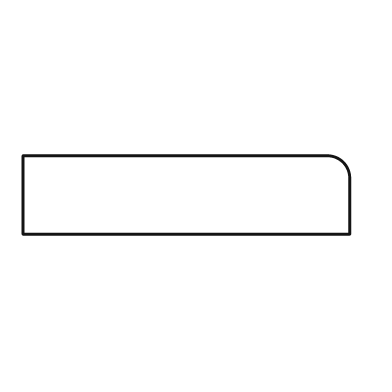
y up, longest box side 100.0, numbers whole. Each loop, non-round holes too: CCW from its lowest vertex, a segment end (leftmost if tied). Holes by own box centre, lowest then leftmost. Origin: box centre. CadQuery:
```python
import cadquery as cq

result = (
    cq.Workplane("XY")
    .moveTo(-50.0, -12.0)
    .lineTo(50.0, -12.0)
    .lineTo(50.0, 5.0)
    .threePointArc((48.0, 10.0), (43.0, 12.0))
    .lineTo(-50.0, 12.0)
    .close()
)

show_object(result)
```